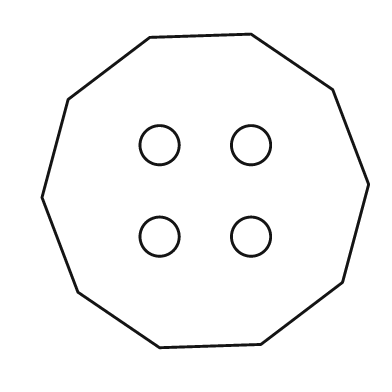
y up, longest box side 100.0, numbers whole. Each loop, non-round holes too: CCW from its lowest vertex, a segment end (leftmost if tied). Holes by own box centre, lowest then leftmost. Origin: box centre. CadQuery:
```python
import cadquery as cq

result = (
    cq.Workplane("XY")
    .moveTo(-14.0, -48.0)
    .lineTo(17.0, -47.0)
    .lineTo(42.0, -28.0)
    .lineTo(50.0, 2.0)
    .lineTo(39.0, 31.0)
    .lineTo(14.0, 48.0)
    .lineTo(-17.0, 47.0)
    .lineTo(-42.0, 28.0)
    .lineTo(-50.0, -2.0)
    .lineTo(-39.0, -31.0)
    .close()
    .moveTo(-14.0, -14.0)
    .circle(6.0)
    .moveTo(14.0, -14.0)
    .circle(6.0)
    .moveTo(-14.0, 14.0)
    .circle(6.0)
    .moveTo(14.0, 14.0)
    .circle(6.0)
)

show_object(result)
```